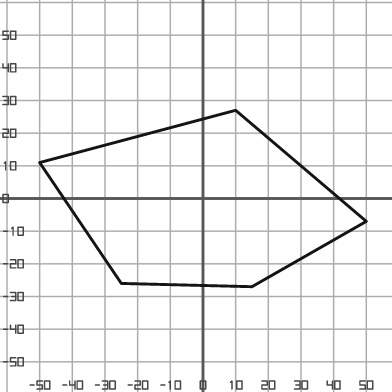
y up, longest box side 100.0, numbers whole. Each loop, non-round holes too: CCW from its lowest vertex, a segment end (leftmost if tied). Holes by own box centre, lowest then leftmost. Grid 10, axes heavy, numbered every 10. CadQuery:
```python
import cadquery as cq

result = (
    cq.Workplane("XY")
    .moveTo(15.0, -27.0)
    .lineTo(50.0, -7.0)
    .lineTo(10.0, 27.0)
    .lineTo(-50.0, 11.0)
    .lineTo(-25.0, -26.0)
    .close()
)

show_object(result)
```